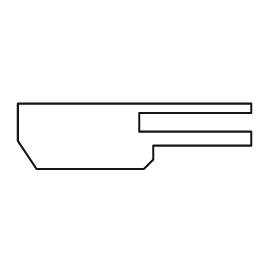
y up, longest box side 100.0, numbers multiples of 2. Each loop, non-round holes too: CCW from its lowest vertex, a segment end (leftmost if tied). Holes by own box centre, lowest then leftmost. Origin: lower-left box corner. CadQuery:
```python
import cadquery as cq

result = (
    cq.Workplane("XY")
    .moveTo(8.0, 0.0)
    .lineTo(54.0, 0.0)
    .lineTo(58.0, 4.0)
    .lineTo(58.0, 10.0)
    .lineTo(100.0, 10.0)
    .lineTo(100.0, 16.0)
    .lineTo(52.0, 16.0)
    .lineTo(52.0, 24.0)
    .lineTo(100.0, 24.0)
    .lineTo(100.0, 28.0)
    .lineTo(0.0, 28.0)
    .lineTo(0.0, 12.0)
    .close()
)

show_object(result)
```